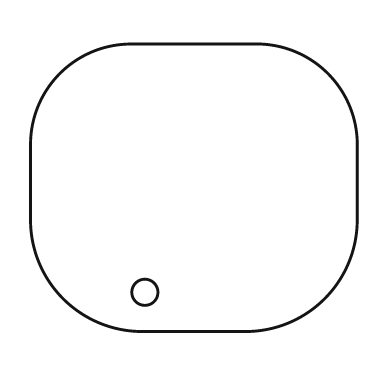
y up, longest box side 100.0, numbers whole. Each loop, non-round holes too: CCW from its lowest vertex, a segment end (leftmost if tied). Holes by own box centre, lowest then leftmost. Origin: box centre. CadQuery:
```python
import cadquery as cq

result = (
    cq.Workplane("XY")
    .moveTo(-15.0, -44.0)
    .lineTo(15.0, -44.0)
    .threePointArc((40.0, -34.0), (50.0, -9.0))
    .lineTo(50.0, 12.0)
    .threePointArc((41.0, 35.0), (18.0, 44.0))
    .lineTo(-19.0, 44.0)
    .threePointArc((-41.0, 35.0), (-50.0, 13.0))
    .lineTo(-50.0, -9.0)
    .threePointArc((-40.0, -34.0), (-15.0, -44.0))
    .close()
    .moveTo(-15.0, -32.0)
    .circle(4.0)
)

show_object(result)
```